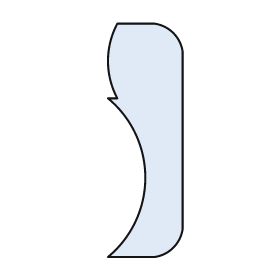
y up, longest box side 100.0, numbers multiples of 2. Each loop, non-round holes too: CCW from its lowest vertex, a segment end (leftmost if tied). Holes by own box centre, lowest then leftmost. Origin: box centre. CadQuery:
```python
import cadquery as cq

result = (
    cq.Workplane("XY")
    .moveTo(-16.0, -50.0)
    .lineTo(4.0, -50.0)
    .threePointArc((12.0, -46.0), (16.0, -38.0))
    .lineTo(16.0, 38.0)
    .threePointArc((12.0, 46.0), (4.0, 50.0))
    .lineTo(-12.0, 50.0)
    .threePointArc((-16.0, 34.0), (-12.0, 18.0))
    .lineTo(-16.0, 18.0)
    .threePointArc((0.0, -16.0), (-16.0, -50.0))
    .close()
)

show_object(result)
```